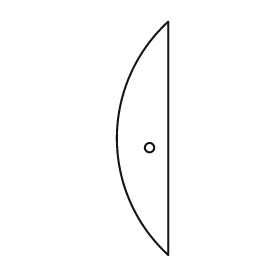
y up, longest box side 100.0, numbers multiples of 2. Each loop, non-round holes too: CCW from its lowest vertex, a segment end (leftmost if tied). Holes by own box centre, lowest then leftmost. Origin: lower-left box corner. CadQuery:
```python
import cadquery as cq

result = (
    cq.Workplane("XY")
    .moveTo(22.0, 0.0)
    .lineTo(22.0, 100.0)
    .threePointArc((0.0, 50.0), (22.0, 0.0))
    .close()
    .moveTo(14.0, 46.0)
    .circle(2.0)
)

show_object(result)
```